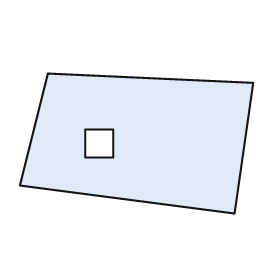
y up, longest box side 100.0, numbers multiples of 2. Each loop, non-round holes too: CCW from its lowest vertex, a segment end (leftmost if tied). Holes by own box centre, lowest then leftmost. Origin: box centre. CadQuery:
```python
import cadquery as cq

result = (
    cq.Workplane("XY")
    .moveTo(42.0, -30.0)
    .lineTo(50.0, 26.0)
    .lineTo(-38.0, 30.0)
    .lineTo(-50.0, -18.0)
    .close()
    .moveTo(-22.0, -6.0)
    .lineTo(-10.0, -6.0)
    .lineTo(-10.0, 6.0)
    .lineTo(-22.0, 6.0)
    .close()
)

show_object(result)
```